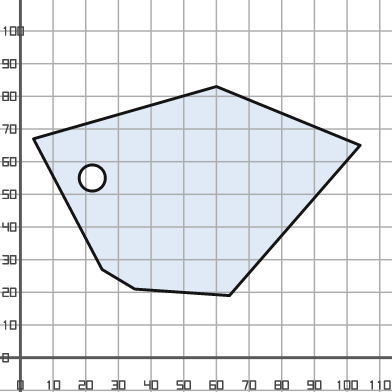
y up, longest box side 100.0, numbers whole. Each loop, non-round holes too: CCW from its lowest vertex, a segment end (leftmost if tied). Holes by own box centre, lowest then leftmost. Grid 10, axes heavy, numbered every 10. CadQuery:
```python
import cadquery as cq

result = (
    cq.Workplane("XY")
    .moveTo(64.0, 19.0)
    .lineTo(104.0, 65.0)
    .lineTo(60.0, 83.0)
    .lineTo(4.0, 67.0)
    .lineTo(25.0, 27.0)
    .lineTo(35.0, 21.0)
    .close()
    .moveTo(22.0, 55.0)
    .circle(4.0)
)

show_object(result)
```